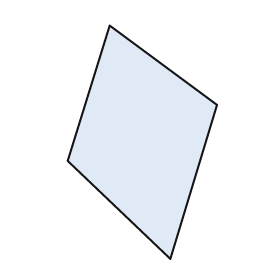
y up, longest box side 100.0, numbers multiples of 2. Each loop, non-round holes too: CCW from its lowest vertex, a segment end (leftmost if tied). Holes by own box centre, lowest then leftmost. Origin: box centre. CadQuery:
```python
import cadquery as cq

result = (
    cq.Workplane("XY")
    .moveTo(12.0, -50.0)
    .lineTo(32.0, 16.0)
    .lineTo(-14.0, 50.0)
    .lineTo(-32.0, -8.0)
    .close()
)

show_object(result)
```